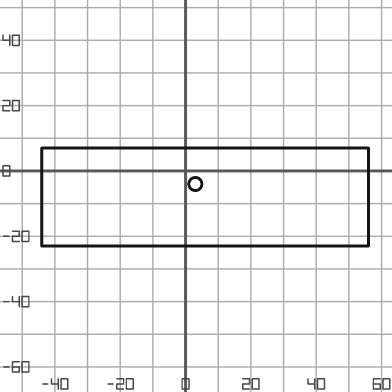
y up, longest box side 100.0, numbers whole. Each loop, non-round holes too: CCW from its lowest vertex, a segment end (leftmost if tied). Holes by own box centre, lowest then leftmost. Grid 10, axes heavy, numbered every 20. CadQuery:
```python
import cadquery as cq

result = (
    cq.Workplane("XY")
    .moveTo(-44.0, -23.0)
    .lineTo(56.0, -23.0)
    .lineTo(56.0, 7.0)
    .lineTo(-44.0, 7.0)
    .close()
    .moveTo(3.0, -4.0)
    .circle(2.0)
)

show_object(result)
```